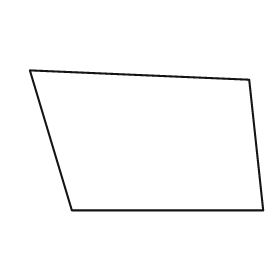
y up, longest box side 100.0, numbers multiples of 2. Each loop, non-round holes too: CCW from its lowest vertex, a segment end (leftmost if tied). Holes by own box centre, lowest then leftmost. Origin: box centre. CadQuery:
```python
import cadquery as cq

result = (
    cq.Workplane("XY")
    .moveTo(-32.0, -30.0)
    .lineTo(50.0, -30.0)
    .lineTo(44.0, 26.0)
    .lineTo(-50.0, 30.0)
    .close()
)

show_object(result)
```